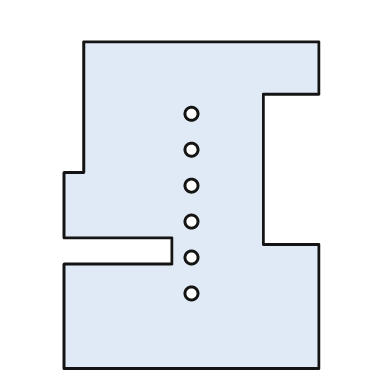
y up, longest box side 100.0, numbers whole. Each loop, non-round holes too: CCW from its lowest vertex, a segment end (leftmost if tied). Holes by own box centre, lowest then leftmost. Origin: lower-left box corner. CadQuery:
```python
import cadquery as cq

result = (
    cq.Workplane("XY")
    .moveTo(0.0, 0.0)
    .lineTo(78.0, 0.0)
    .lineTo(78.0, 38.0)
    .lineTo(61.0, 38.0)
    .lineTo(61.0, 84.0)
    .lineTo(78.0, 84.0)
    .lineTo(78.0, 100.0)
    .lineTo(6.0, 100.0)
    .lineTo(6.0, 60.0)
    .lineTo(0.0, 60.0)
    .lineTo(0.0, 40.0)
    .lineTo(33.0, 40.0)
    .lineTo(33.0, 32.0)
    .lineTo(0.0, 32.0)
    .close()
    .moveTo(39.0, 23.0)
    .circle(2.0)
    .moveTo(39.0, 34.0)
    .circle(2.0)
    .moveTo(39.0, 45.0)
    .circle(2.0)
    .moveTo(39.0, 56.0)
    .circle(2.0)
    .moveTo(39.0, 67.0)
    .circle(2.0)
    .moveTo(39.0, 78.0)
    .circle(2.0)
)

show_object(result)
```